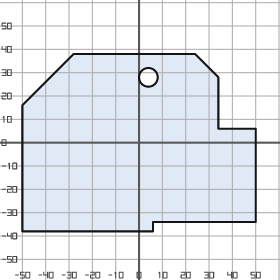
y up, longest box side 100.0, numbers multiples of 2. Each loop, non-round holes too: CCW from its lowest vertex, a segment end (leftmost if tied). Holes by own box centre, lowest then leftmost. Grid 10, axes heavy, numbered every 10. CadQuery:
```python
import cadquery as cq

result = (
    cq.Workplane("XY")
    .moveTo(-50.0, -38.0)
    .lineTo(6.0, -38.0)
    .lineTo(6.0, -34.0)
    .lineTo(50.0, -34.0)
    .lineTo(50.0, 6.0)
    .lineTo(34.0, 6.0)
    .lineTo(34.0, 28.0)
    .lineTo(24.0, 38.0)
    .lineTo(-28.0, 38.0)
    .lineTo(-50.0, 16.0)
    .close()
    .moveTo(4.0, 28.0)
    .circle(4.0)
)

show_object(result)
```